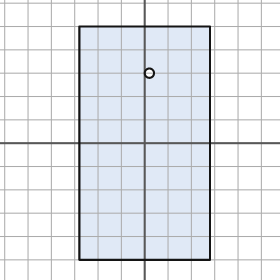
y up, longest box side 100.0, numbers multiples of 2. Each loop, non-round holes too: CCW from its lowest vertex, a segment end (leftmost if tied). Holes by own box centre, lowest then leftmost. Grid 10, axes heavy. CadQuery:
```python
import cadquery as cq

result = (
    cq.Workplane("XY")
    .moveTo(-28.0, -50.0)
    .lineTo(28.0, -50.0)
    .lineTo(28.0, 50.0)
    .lineTo(-28.0, 50.0)
    .close()
    .moveTo(2.0, 30.0)
    .circle(2.0)
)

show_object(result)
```